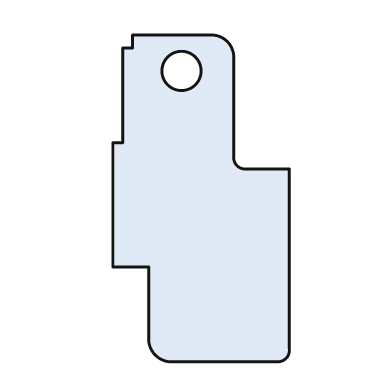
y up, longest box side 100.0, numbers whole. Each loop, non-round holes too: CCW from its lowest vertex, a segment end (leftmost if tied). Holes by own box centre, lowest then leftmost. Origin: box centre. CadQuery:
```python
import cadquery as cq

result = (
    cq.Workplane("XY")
    .moveTo(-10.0, -50.0)
    .lineTo(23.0, -50.0)
    .threePointArc((26.0, -49.0), (27.0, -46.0))
    .lineTo(27.0, 9.0)
    .lineTo(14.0, 9.0)
    .threePointArc((11.0, 10.0), (10.0, 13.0))
    .lineTo(10.0, 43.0)
    .threePointArc((8.0, 48.0), (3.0, 50.0))
    .lineTo(-21.0, 50.0)
    .lineTo(-21.0, 46.0)
    .lineTo(-24.0, 46.0)
    .lineTo(-24.0, 17.0)
    .lineTo(-27.0, 17.0)
    .lineTo(-27.0, -21.0)
    .lineTo(-16.0, -21.0)
    .lineTo(-16.0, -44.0)
    .threePointArc((-14.0, -48.0), (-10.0, -50.0))
    .close()
    .moveTo(-6.0, 39.0)
    .circle(6.0)
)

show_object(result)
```